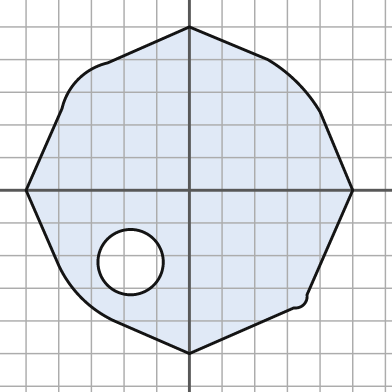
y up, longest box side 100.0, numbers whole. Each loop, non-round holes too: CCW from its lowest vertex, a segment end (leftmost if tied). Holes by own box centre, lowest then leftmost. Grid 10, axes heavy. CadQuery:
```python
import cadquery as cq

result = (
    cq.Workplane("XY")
    .moveTo(0.0, -50.0)
    .lineTo(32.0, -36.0)
    .threePointArc((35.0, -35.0), (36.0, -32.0))
    .lineTo(50.0, 0.0)
    .lineTo(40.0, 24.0)
    .threePointArc((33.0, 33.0), (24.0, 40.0))
    .lineTo(0.0, 50.0)
    .lineTo(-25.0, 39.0)
    .threePointArc((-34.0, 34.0), (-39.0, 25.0))
    .lineTo(-50.0, 0.0)
    .lineTo(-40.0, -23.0)
    .threePointArc((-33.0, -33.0), (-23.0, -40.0))
    .close()
    .moveTo(-18.0, -22.0)
    .circle(10.0)
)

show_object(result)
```